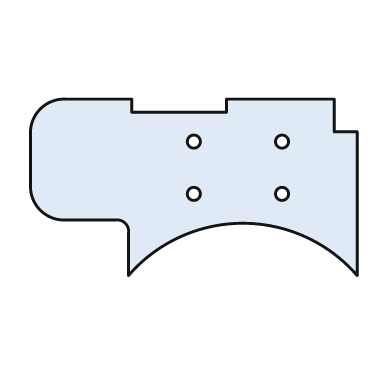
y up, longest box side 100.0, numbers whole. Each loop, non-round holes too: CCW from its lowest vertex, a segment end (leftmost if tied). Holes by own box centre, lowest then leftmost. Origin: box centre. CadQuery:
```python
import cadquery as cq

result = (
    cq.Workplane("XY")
    .moveTo(-20.0, -27.0)
    .threePointArc((15.0, -11.0), (50.0, -27.0))
    .lineTo(50.0, 17.0)
    .lineTo(43.0, 17.0)
    .lineTo(43.0, 27.0)
    .lineTo(10.0, 27.0)
    .lineTo(10.0, 23.0)
    .lineTo(-19.0, 23.0)
    .lineTo(-19.0, 27.0)
    .lineTo(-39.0, 27.0)
    .threePointArc((-47.0, 24.0), (-50.0, 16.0))
    .lineTo(-50.0, 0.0)
    .threePointArc((-47.0, -7.0), (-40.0, -10.0))
    .lineTo(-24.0, -10.0)
    .threePointArc((-21.0, -11.0), (-20.0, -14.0))
    .close()
    .moveTo(0.0, -2.0)
    .circle(2.0)
    .moveTo(27.0, -2.0)
    .circle(2.0)
    .moveTo(0.0, 14.0)
    .circle(2.0)
    .moveTo(27.0, 14.0)
    .circle(2.0)
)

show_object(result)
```